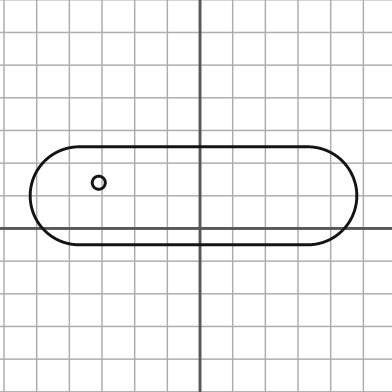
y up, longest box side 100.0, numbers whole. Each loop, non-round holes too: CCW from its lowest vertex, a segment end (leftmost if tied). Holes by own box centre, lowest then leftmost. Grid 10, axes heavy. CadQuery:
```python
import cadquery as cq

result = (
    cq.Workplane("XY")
    .moveTo(-37.0, -5.0)
    .lineTo(33.0, -5.0)
    .threePointArc((48.0, 10.0), (33.0, 25.0))
    .lineTo(-37.0, 25.0)
    .threePointArc((-52.0, 10.0), (-37.0, -5.0))
    .close()
    .moveTo(-31.0, 14.0)
    .circle(2.0)
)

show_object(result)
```